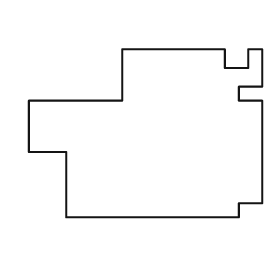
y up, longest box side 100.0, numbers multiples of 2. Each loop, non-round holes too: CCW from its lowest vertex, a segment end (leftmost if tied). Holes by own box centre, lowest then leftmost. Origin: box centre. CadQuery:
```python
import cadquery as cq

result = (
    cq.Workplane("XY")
    .moveTo(-34.0, -36.0)
    .lineTo(40.0, -36.0)
    .lineTo(40.0, -30.0)
    .lineTo(50.0, -30.0)
    .lineTo(50.0, 14.0)
    .lineTo(40.0, 14.0)
    .lineTo(40.0, 20.0)
    .lineTo(50.0, 20.0)
    .lineTo(50.0, 36.0)
    .lineTo(44.0, 36.0)
    .lineTo(44.0, 28.0)
    .lineTo(34.0, 28.0)
    .lineTo(34.0, 36.0)
    .lineTo(-10.0, 36.0)
    .lineTo(-10.0, 14.0)
    .lineTo(-50.0, 14.0)
    .lineTo(-50.0, -8.0)
    .lineTo(-34.0, -8.0)
    .close()
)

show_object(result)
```